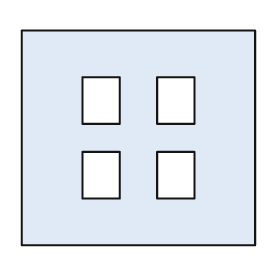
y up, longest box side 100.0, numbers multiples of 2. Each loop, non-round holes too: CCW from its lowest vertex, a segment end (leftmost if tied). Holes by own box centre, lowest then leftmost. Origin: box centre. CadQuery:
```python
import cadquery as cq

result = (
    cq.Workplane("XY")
    .moveTo(-50.0, -46.0)
    .lineTo(50.0, -46.0)
    .lineTo(50.0, 46.0)
    .lineTo(-50.0, 46.0)
    .close()
    .moveTo(-24.0, -26.0)
    .lineTo(-8.0, -26.0)
    .lineTo(-8.0, -6.0)
    .lineTo(-24.0, -6.0)
    .close()
    .moveTo(8.0, -26.0)
    .lineTo(24.0, -26.0)
    .lineTo(24.0, -6.0)
    .lineTo(8.0, -6.0)
    .close()
    .moveTo(-24.0, 6.0)
    .lineTo(-8.0, 6.0)
    .lineTo(-8.0, 26.0)
    .lineTo(-24.0, 26.0)
    .close()
    .moveTo(8.0, 6.0)
    .lineTo(24.0, 6.0)
    .lineTo(24.0, 26.0)
    .lineTo(8.0, 26.0)
    .close()
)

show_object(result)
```